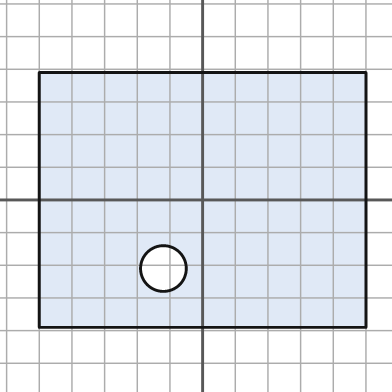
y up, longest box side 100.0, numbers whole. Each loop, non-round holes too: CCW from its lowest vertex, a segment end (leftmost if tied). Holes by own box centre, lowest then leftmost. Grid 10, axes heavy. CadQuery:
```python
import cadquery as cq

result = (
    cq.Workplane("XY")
    .moveTo(-50.0, -39.0)
    .lineTo(50.0, -39.0)
    .lineTo(50.0, 39.0)
    .lineTo(-50.0, 39.0)
    .close()
    .moveTo(-12.0, -21.0)
    .circle(7.0)
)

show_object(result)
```